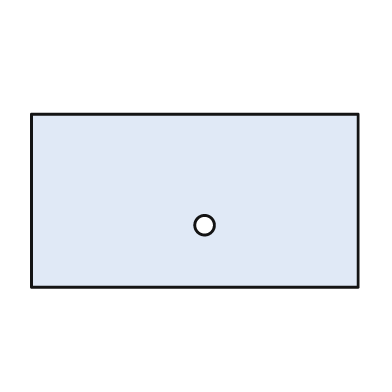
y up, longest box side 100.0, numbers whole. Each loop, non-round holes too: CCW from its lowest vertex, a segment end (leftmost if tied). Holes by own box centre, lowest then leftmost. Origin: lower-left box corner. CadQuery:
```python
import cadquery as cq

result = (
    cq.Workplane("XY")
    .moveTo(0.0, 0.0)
    .lineTo(100.0, 0.0)
    .lineTo(100.0, 53.0)
    .lineTo(0.0, 53.0)
    .close()
    .moveTo(53.0, 19.0)
    .circle(3.0)
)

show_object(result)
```